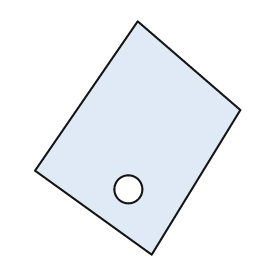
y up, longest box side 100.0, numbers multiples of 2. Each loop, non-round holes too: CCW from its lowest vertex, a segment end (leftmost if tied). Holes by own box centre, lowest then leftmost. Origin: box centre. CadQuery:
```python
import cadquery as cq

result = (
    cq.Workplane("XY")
    .moveTo(6.0, -50.0)
    .lineTo(44.0, 12.0)
    .lineTo(0.0, 50.0)
    .lineTo(-44.0, -14.0)
    .close()
    .moveTo(-4.0, -22.0)
    .circle(6.0)
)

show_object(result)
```